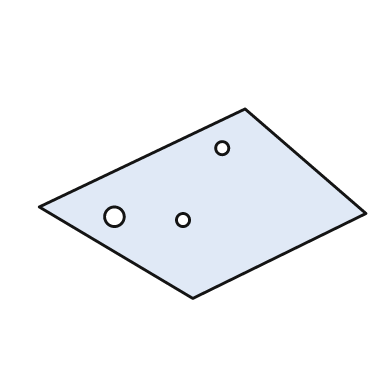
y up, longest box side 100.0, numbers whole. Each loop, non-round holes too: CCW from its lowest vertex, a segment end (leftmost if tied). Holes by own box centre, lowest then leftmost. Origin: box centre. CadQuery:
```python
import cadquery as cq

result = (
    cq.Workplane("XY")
    .moveTo(-3.0, -29.0)
    .lineTo(50.0, -3.0)
    .lineTo(13.0, 29.0)
    .lineTo(-50.0, -1.0)
    .close()
    .moveTo(-6.0, -5.0)
    .circle(2.0)
    .moveTo(-27.0, -4.0)
    .circle(3.0)
    .moveTo(6.0, 17.0)
    .circle(2.0)
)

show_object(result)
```